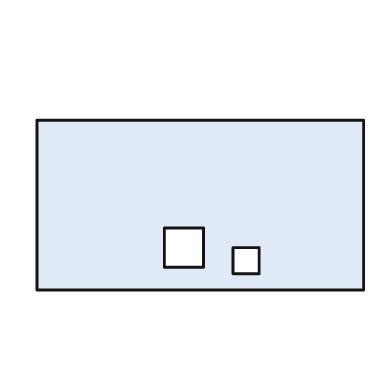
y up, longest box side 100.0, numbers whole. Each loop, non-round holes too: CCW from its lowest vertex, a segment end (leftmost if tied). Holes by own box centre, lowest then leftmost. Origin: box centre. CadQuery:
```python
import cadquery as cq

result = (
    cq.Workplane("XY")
    .moveTo(-50.0, -26.0)
    .lineTo(50.0, -26.0)
    .lineTo(50.0, 26.0)
    .lineTo(-50.0, 26.0)
    .close()
    .moveTo(10.0, -21.0)
    .lineTo(18.0, -21.0)
    .lineTo(18.0, -13.0)
    .lineTo(10.0, -13.0)
    .close()
    .moveTo(-11.0, -19.0)
    .lineTo(1.0, -19.0)
    .lineTo(1.0, -7.0)
    .lineTo(-11.0, -7.0)
    .close()
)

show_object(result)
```